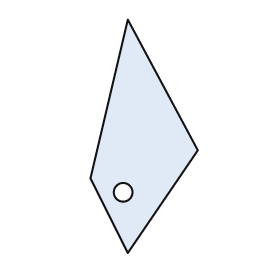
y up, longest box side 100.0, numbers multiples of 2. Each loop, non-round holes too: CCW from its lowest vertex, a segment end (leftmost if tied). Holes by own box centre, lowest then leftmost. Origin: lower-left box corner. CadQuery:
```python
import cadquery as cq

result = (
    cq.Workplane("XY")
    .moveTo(16.0, 0.0)
    .lineTo(46.0, 44.0)
    .lineTo(16.0, 100.0)
    .lineTo(0.0, 32.0)
    .close()
    .moveTo(14.0, 26.0)
    .circle(4.0)
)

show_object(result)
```